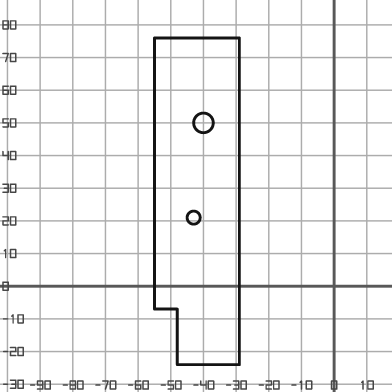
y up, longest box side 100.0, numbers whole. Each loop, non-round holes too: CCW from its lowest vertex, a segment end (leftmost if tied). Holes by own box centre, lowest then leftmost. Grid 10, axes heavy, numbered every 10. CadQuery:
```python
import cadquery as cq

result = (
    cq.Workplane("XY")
    .moveTo(-48.0, -24.0)
    .lineTo(-29.0, -24.0)
    .lineTo(-29.0, 76.0)
    .lineTo(-55.0, 76.0)
    .lineTo(-55.0, -7.0)
    .lineTo(-48.0, -7.0)
    .close()
    .moveTo(-43.0, 21.0)
    .circle(2.0)
    .moveTo(-40.0, 50.0)
    .circle(3.0)
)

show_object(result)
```